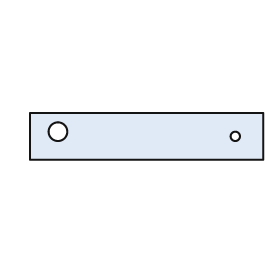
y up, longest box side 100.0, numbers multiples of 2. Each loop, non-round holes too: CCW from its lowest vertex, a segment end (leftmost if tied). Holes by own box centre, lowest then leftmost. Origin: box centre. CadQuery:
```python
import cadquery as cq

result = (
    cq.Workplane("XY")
    .moveTo(-50.0, -10.0)
    .lineTo(50.0, -10.0)
    .lineTo(50.0, 10.0)
    .lineTo(-50.0, 10.0)
    .close()
    .moveTo(38.0, 0.0)
    .circle(2.0)
    .moveTo(-38.0, 2.0)
    .circle(4.0)
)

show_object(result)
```